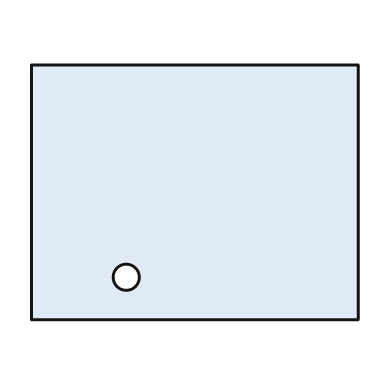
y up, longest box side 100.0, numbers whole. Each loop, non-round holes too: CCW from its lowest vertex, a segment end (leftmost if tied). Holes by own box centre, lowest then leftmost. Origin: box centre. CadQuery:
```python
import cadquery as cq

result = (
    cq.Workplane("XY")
    .moveTo(-50.0, -39.0)
    .lineTo(50.0, -39.0)
    .lineTo(50.0, 39.0)
    .lineTo(-50.0, 39.0)
    .close()
    .moveTo(-21.0, -26.0)
    .circle(4.0)
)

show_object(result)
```